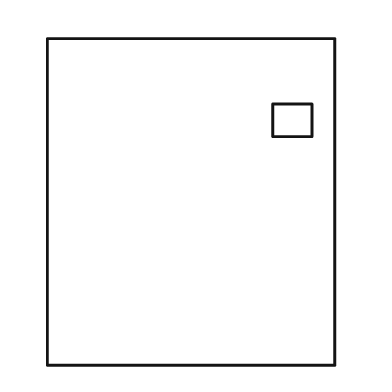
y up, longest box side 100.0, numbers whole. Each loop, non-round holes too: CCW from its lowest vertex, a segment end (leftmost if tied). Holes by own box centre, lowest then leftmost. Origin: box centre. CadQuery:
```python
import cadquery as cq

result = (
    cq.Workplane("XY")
    .moveTo(-44.0, -50.0)
    .lineTo(44.0, -50.0)
    .lineTo(44.0, 50.0)
    .lineTo(-44.0, 50.0)
    .close()
    .moveTo(25.0, 20.0)
    .lineTo(37.0, 20.0)
    .lineTo(37.0, 30.0)
    .lineTo(25.0, 30.0)
    .close()
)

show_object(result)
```